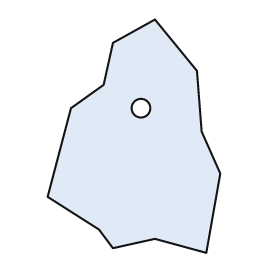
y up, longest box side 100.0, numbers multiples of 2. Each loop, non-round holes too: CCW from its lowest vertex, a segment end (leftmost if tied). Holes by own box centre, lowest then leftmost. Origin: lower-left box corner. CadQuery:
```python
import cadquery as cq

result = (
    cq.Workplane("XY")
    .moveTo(68.0, 0.0)
    .lineTo(74.0, 34.0)
    .lineTo(66.0, 52.0)
    .lineTo(64.0, 78.0)
    .lineTo(46.0, 100.0)
    .lineTo(28.0, 90.0)
    .lineTo(24.0, 72.0)
    .lineTo(10.0, 62.0)
    .lineTo(0.0, 24.0)
    .lineTo(22.0, 10.0)
    .lineTo(28.0, 2.0)
    .lineTo(46.0, 6.0)
    .close()
    .moveTo(40.0, 62.0)
    .circle(4.0)
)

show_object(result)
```